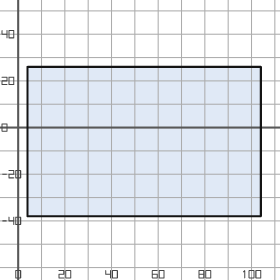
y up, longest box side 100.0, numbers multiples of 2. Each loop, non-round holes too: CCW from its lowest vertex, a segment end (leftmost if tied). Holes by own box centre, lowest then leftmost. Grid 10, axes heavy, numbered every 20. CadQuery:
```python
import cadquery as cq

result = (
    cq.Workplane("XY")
    .moveTo(4.0, -38.0)
    .lineTo(104.0, -38.0)
    .lineTo(104.0, 26.0)
    .lineTo(4.0, 26.0)
    .close()
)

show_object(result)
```